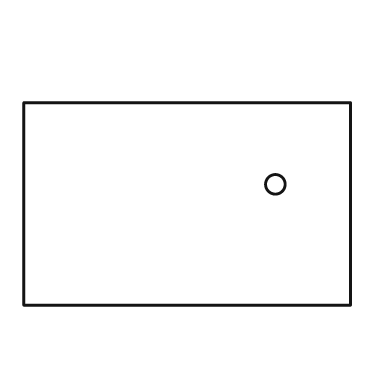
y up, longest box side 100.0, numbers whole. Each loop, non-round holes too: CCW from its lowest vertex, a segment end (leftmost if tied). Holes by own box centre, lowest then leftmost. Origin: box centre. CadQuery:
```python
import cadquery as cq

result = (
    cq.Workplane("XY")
    .moveTo(-50.0, -31.0)
    .lineTo(50.0, -31.0)
    .lineTo(50.0, 31.0)
    .lineTo(-50.0, 31.0)
    .close()
    .moveTo(27.0, 6.0)
    .circle(3.0)
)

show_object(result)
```